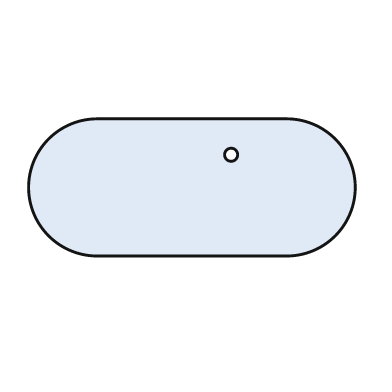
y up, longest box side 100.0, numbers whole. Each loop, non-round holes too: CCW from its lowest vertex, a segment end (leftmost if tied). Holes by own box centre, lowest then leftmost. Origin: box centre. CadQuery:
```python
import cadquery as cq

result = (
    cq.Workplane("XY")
    .moveTo(-29.0, -21.0)
    .lineTo(29.0, -21.0)
    .threePointArc((50.0, 0.0), (29.0, 21.0))
    .lineTo(-29.0, 21.0)
    .threePointArc((-50.0, 0.0), (-29.0, -21.0))
    .close()
    .moveTo(12.0, 10.0)
    .circle(2.0)
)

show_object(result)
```